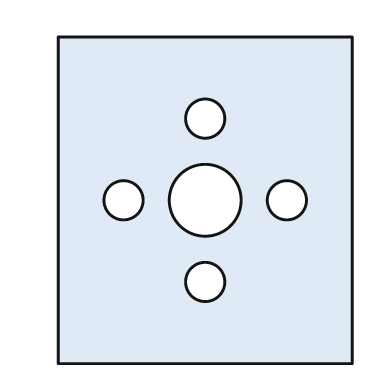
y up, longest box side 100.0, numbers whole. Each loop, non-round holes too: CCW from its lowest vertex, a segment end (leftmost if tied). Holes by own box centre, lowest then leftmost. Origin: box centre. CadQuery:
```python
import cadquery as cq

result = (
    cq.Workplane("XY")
    .moveTo(-45.0, -50.0)
    .lineTo(45.0, -50.0)
    .lineTo(45.0, 50.0)
    .lineTo(-45.0, 50.0)
    .close()
    .moveTo(0.0, -25.0)
    .circle(6.0)
    .moveTo(-25.0, 0.0)
    .circle(6.0)
    .moveTo(0.0, 0.0)
    .circle(11.0)
    .moveTo(25.0, 0.0)
    .circle(6.0)
    .moveTo(0.0, 25.0)
    .circle(6.0)
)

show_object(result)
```